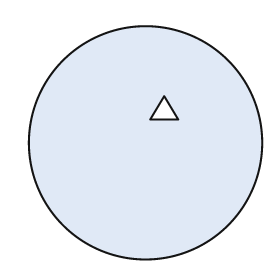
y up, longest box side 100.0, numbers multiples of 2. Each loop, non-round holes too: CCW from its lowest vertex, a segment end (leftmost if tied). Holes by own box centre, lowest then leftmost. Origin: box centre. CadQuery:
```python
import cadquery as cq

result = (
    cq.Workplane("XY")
    .moveTo(0.0, 0.0)
    .circle(50.0)
    .moveTo(2.0, 10.0)
    .lineTo(14.0, 10.0)
    .lineTo(8.0, 20.0)
    .close()
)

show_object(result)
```